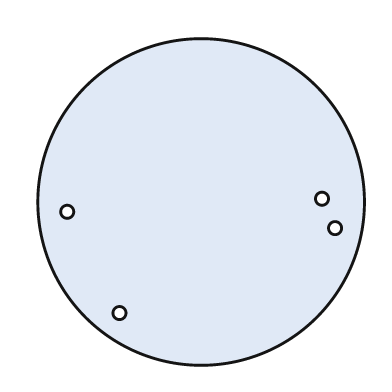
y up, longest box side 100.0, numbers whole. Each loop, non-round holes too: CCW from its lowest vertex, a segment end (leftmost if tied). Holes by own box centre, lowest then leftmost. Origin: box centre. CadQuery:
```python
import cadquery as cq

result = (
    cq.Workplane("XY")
    .moveTo(0.0, 0.0)
    .circle(50.0)
    .moveTo(-25.0, -34.0)
    .circle(2.0)
    .moveTo(41.0, -8.0)
    .circle(2.0)
    .moveTo(-41.0, -3.0)
    .circle(2.0)
    .moveTo(37.0, 1.0)
    .circle(2.0)
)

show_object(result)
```